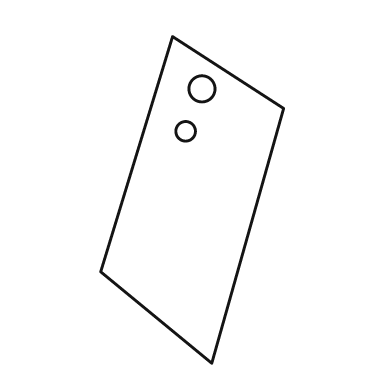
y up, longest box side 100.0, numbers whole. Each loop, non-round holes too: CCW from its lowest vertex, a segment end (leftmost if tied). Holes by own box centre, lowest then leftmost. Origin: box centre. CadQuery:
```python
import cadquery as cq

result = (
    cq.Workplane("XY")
    .moveTo(6.0, -50.0)
    .lineTo(28.0, 28.0)
    .lineTo(-6.0, 50.0)
    .lineTo(-28.0, -22.0)
    .close()
    .moveTo(-2.0, 21.0)
    .circle(3.0)
    .moveTo(3.0, 34.0)
    .circle(4.0)
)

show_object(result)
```